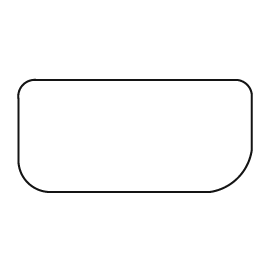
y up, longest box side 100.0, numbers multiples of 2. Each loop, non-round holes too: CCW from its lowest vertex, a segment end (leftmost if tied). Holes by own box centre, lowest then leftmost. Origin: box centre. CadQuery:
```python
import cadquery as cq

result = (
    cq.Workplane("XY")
    .moveTo(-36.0, -24.0)
    .lineTo(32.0, -24.0)
    .threePointArc((44.0, -18.0), (50.0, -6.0))
    .lineTo(50.0, 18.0)
    .threePointArc((48.0, 22.0), (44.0, 24.0))
    .lineTo(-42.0, 24.0)
    .threePointArc((-48.0, 22.0), (-50.0, 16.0))
    .lineTo(-50.0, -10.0)
    .threePointArc((-46.0, -20.0), (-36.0, -24.0))
    .close()
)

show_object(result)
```